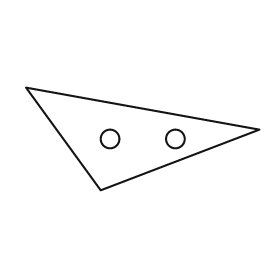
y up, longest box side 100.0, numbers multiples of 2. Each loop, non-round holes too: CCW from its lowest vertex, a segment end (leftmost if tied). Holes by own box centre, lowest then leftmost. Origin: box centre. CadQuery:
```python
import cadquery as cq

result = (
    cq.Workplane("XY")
    .moveTo(-18.0, -22.0)
    .lineTo(50.0, 4.0)
    .lineTo(-50.0, 22.0)
    .close()
    .moveTo(-14.0, 0.0)
    .circle(4.0)
    .moveTo(14.0, 0.0)
    .circle(4.0)
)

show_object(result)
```